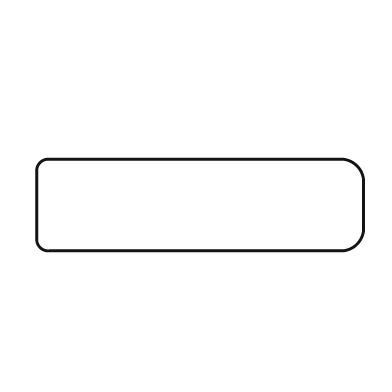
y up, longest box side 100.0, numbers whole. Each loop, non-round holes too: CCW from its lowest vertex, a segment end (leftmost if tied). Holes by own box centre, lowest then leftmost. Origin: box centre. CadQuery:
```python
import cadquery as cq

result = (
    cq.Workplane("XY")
    .moveTo(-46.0, -14.0)
    .lineTo(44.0, -14.0)
    .threePointArc((48.0, -12.0), (50.0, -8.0))
    .lineTo(50.0, 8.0)
    .threePointArc((48.0, 12.0), (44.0, 14.0))
    .lineTo(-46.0, 14.0)
    .threePointArc((-49.0, 13.0), (-50.0, 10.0))
    .lineTo(-50.0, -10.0)
    .threePointArc((-49.0, -13.0), (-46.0, -14.0))
    .close()
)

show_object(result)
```